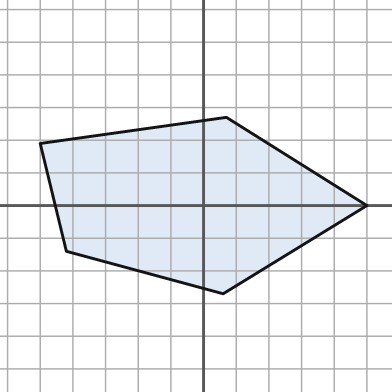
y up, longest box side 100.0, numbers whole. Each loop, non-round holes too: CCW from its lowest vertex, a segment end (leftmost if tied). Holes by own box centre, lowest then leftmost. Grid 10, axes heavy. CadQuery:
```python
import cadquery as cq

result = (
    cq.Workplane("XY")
    .moveTo(6.0, -27.0)
    .lineTo(50.0, 0.0)
    .lineTo(7.0, 27.0)
    .lineTo(-50.0, 19.0)
    .lineTo(-42.0, -14.0)
    .close()
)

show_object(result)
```